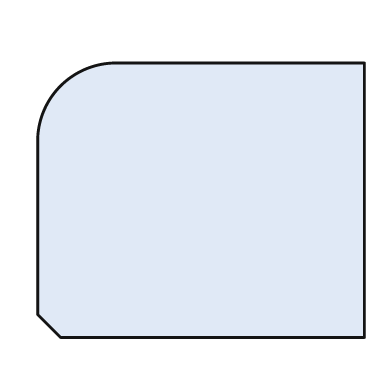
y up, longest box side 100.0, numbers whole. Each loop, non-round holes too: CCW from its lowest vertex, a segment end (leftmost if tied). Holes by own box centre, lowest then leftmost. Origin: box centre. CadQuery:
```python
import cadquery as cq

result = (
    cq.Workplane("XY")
    .moveTo(-43.0, -42.0)
    .lineTo(50.0, -42.0)
    .lineTo(50.0, 42.0)
    .lineTo(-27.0, 42.0)
    .threePointArc((-43.0, 35.0), (-50.0, 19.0))
    .lineTo(-50.0, -35.0)
    .close()
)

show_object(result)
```